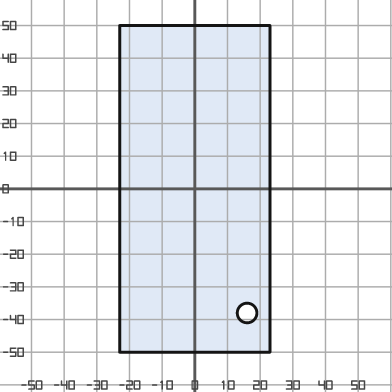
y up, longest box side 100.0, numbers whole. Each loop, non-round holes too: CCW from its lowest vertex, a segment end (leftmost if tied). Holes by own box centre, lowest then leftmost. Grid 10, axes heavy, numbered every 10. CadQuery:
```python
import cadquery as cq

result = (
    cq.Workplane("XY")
    .moveTo(-23.0, -50.0)
    .lineTo(23.0, -50.0)
    .lineTo(23.0, 50.0)
    .lineTo(-23.0, 50.0)
    .close()
    .moveTo(16.0, -38.0)
    .circle(3.0)
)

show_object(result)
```